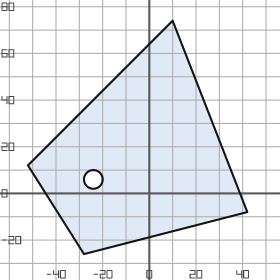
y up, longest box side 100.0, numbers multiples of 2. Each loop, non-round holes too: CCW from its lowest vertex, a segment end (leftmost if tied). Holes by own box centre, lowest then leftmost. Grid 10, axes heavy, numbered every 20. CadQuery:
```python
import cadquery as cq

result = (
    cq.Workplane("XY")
    .moveTo(-28.0, -26.0)
    .lineTo(42.0, -8.0)
    .lineTo(10.0, 74.0)
    .lineTo(-52.0, 12.0)
    .close()
    .moveTo(-24.0, 6.0)
    .circle(4.0)
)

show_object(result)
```